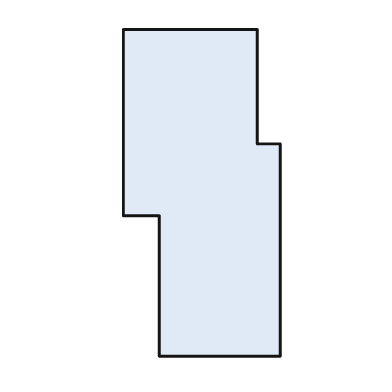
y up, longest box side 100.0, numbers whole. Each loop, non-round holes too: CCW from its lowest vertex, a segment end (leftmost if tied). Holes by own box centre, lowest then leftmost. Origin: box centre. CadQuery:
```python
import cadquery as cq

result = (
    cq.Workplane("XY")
    .moveTo(-13.0, -50.0)
    .lineTo(24.0, -50.0)
    .lineTo(24.0, 15.0)
    .lineTo(17.0, 15.0)
    .lineTo(17.0, 50.0)
    .lineTo(-24.0, 50.0)
    .lineTo(-24.0, -7.0)
    .lineTo(-13.0, -7.0)
    .close()
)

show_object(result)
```